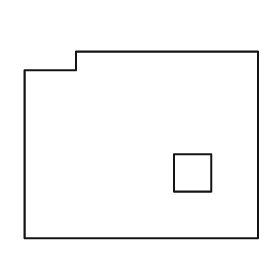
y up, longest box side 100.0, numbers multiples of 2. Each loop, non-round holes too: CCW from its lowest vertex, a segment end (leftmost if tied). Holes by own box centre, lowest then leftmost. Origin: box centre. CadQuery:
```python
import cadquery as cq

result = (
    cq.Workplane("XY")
    .moveTo(-50.0, -40.0)
    .lineTo(50.0, -40.0)
    .lineTo(50.0, 40.0)
    .lineTo(-28.0, 40.0)
    .lineTo(-28.0, 32.0)
    .lineTo(-50.0, 32.0)
    .close()
    .moveTo(14.0, -20.0)
    .lineTo(30.0, -20.0)
    .lineTo(30.0, -4.0)
    .lineTo(14.0, -4.0)
    .close()
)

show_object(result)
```